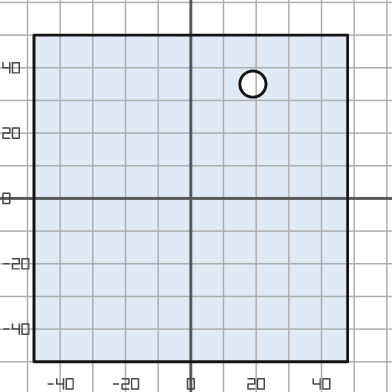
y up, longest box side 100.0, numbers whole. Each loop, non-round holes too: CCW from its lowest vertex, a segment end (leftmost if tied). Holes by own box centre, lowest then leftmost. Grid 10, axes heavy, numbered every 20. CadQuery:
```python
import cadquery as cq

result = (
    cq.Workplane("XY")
    .moveTo(-48.0, -50.0)
    .lineTo(48.0, -50.0)
    .lineTo(48.0, 50.0)
    .lineTo(-48.0, 50.0)
    .close()
    .moveTo(19.0, 35.0)
    .circle(4.0)
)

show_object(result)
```